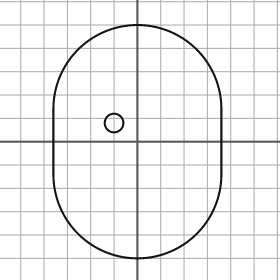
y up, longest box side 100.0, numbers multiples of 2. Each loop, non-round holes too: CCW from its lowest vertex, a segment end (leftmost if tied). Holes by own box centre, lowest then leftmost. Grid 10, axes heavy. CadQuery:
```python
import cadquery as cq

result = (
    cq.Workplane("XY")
    .moveTo(-36.0, -14.0)
    .threePointArc((0.0, -50.0), (36.0, -14.0))
    .lineTo(36.0, 14.0)
    .threePointArc((0.0, 50.0), (-36.0, 14.0))
    .close()
    .moveTo(-10.0, 8.0)
    .circle(4.0)
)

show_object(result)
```